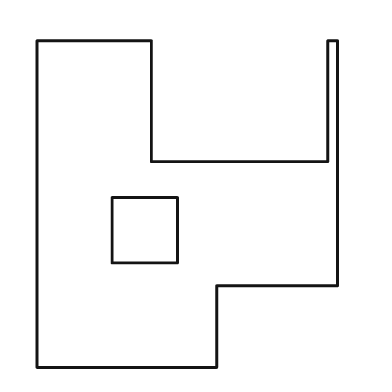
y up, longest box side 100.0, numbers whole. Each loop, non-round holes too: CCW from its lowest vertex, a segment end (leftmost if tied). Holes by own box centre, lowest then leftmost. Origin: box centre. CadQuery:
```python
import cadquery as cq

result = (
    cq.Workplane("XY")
    .moveTo(-46.0, -50.0)
    .lineTo(9.0, -50.0)
    .lineTo(9.0, -25.0)
    .lineTo(46.0, -25.0)
    .lineTo(46.0, 50.0)
    .lineTo(43.0, 50.0)
    .lineTo(43.0, 13.0)
    .lineTo(-11.0, 13.0)
    .lineTo(-11.0, 50.0)
    .lineTo(-46.0, 50.0)
    .close()
    .moveTo(-23.0, -18.0)
    .lineTo(-3.0, -18.0)
    .lineTo(-3.0, 2.0)
    .lineTo(-23.0, 2.0)
    .close()
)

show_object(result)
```